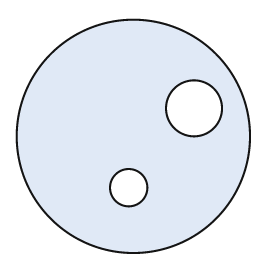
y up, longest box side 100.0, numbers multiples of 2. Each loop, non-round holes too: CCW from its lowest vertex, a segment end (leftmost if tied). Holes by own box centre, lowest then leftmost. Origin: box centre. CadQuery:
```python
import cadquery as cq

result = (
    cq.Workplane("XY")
    .moveTo(0.0, 0.0)
    .circle(50.0)
    .moveTo(-2.0, -22.0)
    .circle(8.0)
    .moveTo(26.0, 12.0)
    .circle(12.0)
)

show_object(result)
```